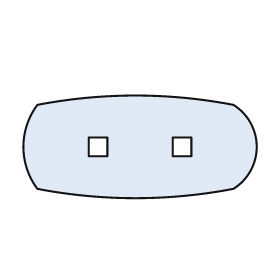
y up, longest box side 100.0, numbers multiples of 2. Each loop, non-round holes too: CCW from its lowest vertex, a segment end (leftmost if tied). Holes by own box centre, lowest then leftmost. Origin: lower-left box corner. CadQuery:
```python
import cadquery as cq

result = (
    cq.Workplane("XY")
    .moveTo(6.0, 4.0)
    .threePointArc((48.0, 0.0), (90.0, 4.0))
    .threePointArc((100.0, 22.0), (90.0, 40.0))
    .threePointArc((48.0, 44.0), (6.0, 40.0))
    .threePointArc((0.0, 22.0), (6.0, 4.0))
    .close()
    .moveTo(28.0, 18.0)
    .lineTo(36.0, 18.0)
    .lineTo(36.0, 26.0)
    .lineTo(28.0, 26.0)
    .close()
    .moveTo(64.0, 18.0)
    .lineTo(72.0, 18.0)
    .lineTo(72.0, 26.0)
    .lineTo(64.0, 26.0)
    .close()
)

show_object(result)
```